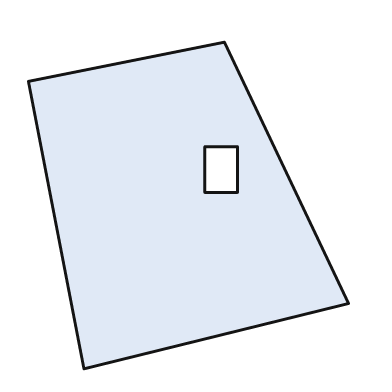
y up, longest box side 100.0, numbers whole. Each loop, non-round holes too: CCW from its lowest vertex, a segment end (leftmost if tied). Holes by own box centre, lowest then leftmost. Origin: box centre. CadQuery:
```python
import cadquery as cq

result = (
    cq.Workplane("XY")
    .moveTo(-32.0, -50.0)
    .lineTo(49.0, -30.0)
    .lineTo(11.0, 50.0)
    .lineTo(-49.0, 38.0)
    .close()
    .moveTo(5.0, 4.0)
    .lineTo(15.0, 4.0)
    .lineTo(15.0, 18.0)
    .lineTo(5.0, 18.0)
    .close()
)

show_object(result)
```